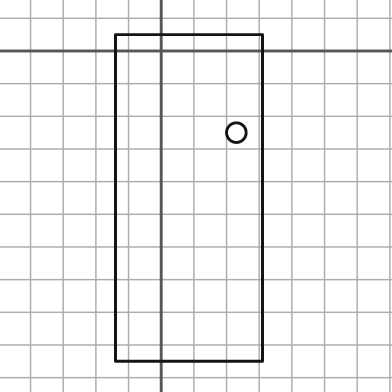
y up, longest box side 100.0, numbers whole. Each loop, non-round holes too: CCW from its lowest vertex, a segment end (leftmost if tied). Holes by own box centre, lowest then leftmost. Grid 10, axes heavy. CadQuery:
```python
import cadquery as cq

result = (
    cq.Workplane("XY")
    .moveTo(-14.0, -95.0)
    .lineTo(31.0, -95.0)
    .lineTo(31.0, 5.0)
    .lineTo(-14.0, 5.0)
    .close()
    .moveTo(23.0, -25.0)
    .circle(3.0)
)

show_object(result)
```